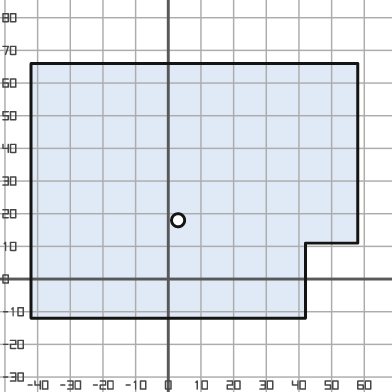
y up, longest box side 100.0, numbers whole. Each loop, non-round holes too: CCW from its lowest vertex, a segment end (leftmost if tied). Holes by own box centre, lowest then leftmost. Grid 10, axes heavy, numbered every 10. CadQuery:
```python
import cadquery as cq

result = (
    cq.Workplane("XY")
    .moveTo(-42.0, -12.0)
    .lineTo(42.0, -12.0)
    .lineTo(42.0, 11.0)
    .lineTo(58.0, 11.0)
    .lineTo(58.0, 66.0)
    .lineTo(-42.0, 66.0)
    .close()
    .moveTo(3.0, 18.0)
    .circle(2.0)
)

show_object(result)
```